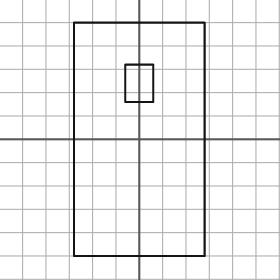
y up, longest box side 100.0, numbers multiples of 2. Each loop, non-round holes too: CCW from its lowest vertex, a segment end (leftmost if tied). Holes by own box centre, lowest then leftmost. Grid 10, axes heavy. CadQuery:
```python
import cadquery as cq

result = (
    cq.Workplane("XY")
    .moveTo(-28.0, -50.0)
    .lineTo(28.0, -50.0)
    .lineTo(28.0, 50.0)
    .lineTo(-28.0, 50.0)
    .close()
    .moveTo(-6.0, 16.0)
    .lineTo(6.0, 16.0)
    .lineTo(6.0, 32.0)
    .lineTo(-6.0, 32.0)
    .close()
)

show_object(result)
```